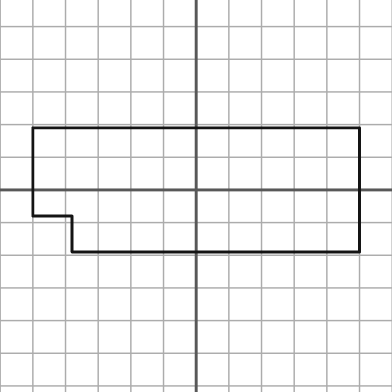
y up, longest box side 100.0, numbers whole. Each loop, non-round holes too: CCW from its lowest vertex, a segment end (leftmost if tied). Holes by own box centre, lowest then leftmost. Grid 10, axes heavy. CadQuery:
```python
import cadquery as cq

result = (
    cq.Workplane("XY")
    .moveTo(-38.0, -19.0)
    .lineTo(50.0, -19.0)
    .lineTo(50.0, 19.0)
    .lineTo(-50.0, 19.0)
    .lineTo(-50.0, -8.0)
    .lineTo(-38.0, -8.0)
    .close()
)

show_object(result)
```